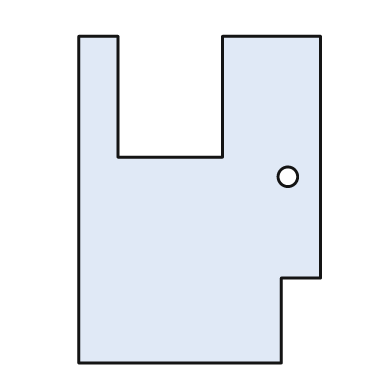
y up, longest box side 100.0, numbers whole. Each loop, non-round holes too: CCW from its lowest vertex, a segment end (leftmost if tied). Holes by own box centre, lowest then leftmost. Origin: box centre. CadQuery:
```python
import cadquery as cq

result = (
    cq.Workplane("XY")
    .moveTo(-37.0, -50.0)
    .lineTo(25.0, -50.0)
    .lineTo(25.0, -24.0)
    .lineTo(37.0, -24.0)
    .lineTo(37.0, 50.0)
    .lineTo(7.0, 50.0)
    .lineTo(7.0, 13.0)
    .lineTo(-25.0, 13.0)
    .lineTo(-25.0, 50.0)
    .lineTo(-37.0, 50.0)
    .close()
    .moveTo(27.0, 7.0)
    .circle(3.0)
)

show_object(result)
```